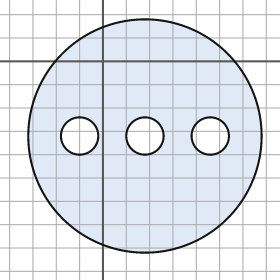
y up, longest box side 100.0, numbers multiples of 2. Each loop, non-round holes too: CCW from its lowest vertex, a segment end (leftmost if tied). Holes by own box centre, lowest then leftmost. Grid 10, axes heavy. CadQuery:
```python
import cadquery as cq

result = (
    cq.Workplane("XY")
    .moveTo(18.0, -32.0)
    .circle(50.0)
    .moveTo(-10.0, -32.0)
    .circle(8.0)
    .moveTo(18.0, -32.0)
    .circle(8.0)
    .moveTo(46.0, -32.0)
    .circle(8.0)
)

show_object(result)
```